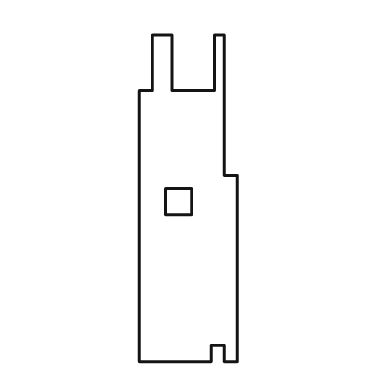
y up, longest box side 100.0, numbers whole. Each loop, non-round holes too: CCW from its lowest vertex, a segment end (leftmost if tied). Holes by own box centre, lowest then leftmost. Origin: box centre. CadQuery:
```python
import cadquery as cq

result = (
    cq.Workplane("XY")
    .moveTo(-15.0, -50.0)
    .lineTo(7.0, -50.0)
    .lineTo(7.0, -45.0)
    .lineTo(11.0, -45.0)
    .lineTo(11.0, -50.0)
    .lineTo(15.0, -50.0)
    .lineTo(15.0, 7.0)
    .lineTo(11.0, 7.0)
    .lineTo(11.0, 50.0)
    .lineTo(8.0, 50.0)
    .lineTo(8.0, 33.0)
    .lineTo(-5.0, 33.0)
    .lineTo(-5.0, 50.0)
    .lineTo(-11.0, 50.0)
    .lineTo(-11.0, 33.0)
    .lineTo(-15.0, 33.0)
    .close()
    .moveTo(-7.0, -5.0)
    .lineTo(1.0, -5.0)
    .lineTo(1.0, 3.0)
    .lineTo(-7.0, 3.0)
    .close()
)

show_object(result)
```